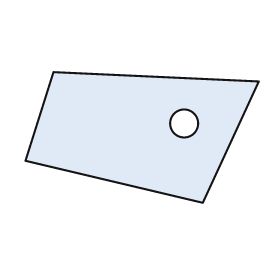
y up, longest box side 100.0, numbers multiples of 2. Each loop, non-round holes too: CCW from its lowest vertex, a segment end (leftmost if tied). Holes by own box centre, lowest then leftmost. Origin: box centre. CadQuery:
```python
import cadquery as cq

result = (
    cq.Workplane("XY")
    .moveTo(26.0, -28.0)
    .lineTo(50.0, 24.0)
    .lineTo(-38.0, 28.0)
    .lineTo(-50.0, -10.0)
    .close()
    .moveTo(18.0, 6.0)
    .circle(6.0)
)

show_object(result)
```